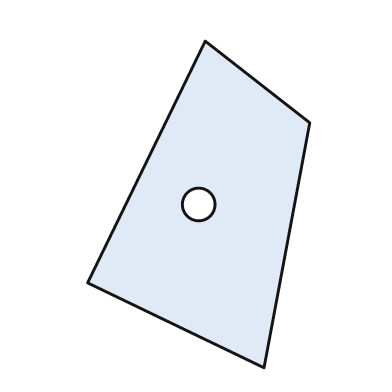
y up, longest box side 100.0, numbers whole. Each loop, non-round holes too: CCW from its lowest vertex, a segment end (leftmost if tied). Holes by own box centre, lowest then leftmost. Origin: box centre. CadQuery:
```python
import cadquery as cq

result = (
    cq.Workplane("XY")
    .moveTo(20.0, -50.0)
    .lineTo(34.0, 25.0)
    .lineTo(2.0, 50.0)
    .lineTo(-34.0, -24.0)
    .close()
    .moveTo(0.0, 0.0)
    .circle(5.0)
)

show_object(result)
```